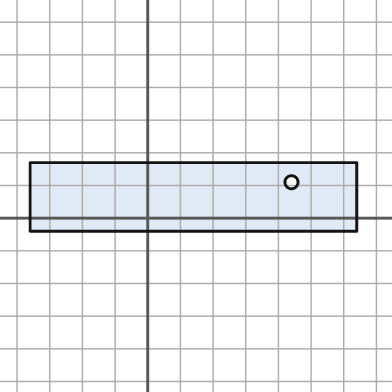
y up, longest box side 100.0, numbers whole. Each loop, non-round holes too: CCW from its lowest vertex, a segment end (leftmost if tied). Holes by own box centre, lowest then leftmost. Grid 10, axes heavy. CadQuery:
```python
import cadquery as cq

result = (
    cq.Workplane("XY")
    .moveTo(-36.0, -4.0)
    .lineTo(64.0, -4.0)
    .lineTo(64.0, 17.0)
    .lineTo(-36.0, 17.0)
    .close()
    .moveTo(44.0, 11.0)
    .circle(2.0)
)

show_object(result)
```